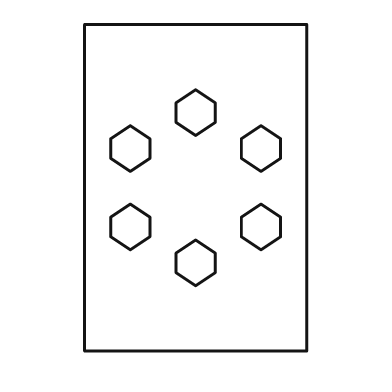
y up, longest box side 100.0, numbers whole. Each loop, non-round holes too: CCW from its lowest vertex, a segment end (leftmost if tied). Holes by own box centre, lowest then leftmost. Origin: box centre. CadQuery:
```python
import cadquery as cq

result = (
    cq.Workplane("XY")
    .moveTo(-34.0, -50.0)
    .lineTo(34.0, -50.0)
    .lineTo(34.0, 50.0)
    .lineTo(-34.0, 50.0)
    .close()
    .moveTo(0.0, -30.0)
    .lineTo(6.0, -26.0)
    .lineTo(6.0, -20.0)
    .lineTo(0.0, -16.0)
    .lineTo(-6.0, -20.0)
    .lineTo(-6.0, -26.0)
    .close()
    .moveTo(-20.0, -19.0)
    .lineTo(-14.0, -15.0)
    .lineTo(-14.0, -9.0)
    .lineTo(-20.0, -5.0)
    .lineTo(-26.0, -9.0)
    .lineTo(-26.0, -15.0)
    .close()
    .moveTo(20.0, -19.0)
    .lineTo(26.0, -15.0)
    .lineTo(26.0, -9.0)
    .lineTo(20.0, -5.0)
    .lineTo(14.0, -9.0)
    .lineTo(14.0, -15.0)
    .close()
    .moveTo(-20.0, 5.0)
    .lineTo(-14.0, 9.0)
    .lineTo(-14.0, 15.0)
    .lineTo(-20.0, 19.0)
    .lineTo(-26.0, 15.0)
    .lineTo(-26.0, 9.0)
    .close()
    .moveTo(20.0, 5.0)
    .lineTo(26.0, 9.0)
    .lineTo(26.0, 15.0)
    .lineTo(20.0, 19.0)
    .lineTo(14.0, 15.0)
    .lineTo(14.0, 9.0)
    .close()
    .moveTo(0.0, 16.0)
    .lineTo(6.0, 20.0)
    .lineTo(6.0, 26.0)
    .lineTo(0.0, 30.0)
    .lineTo(-6.0, 26.0)
    .lineTo(-6.0, 20.0)
    .close()
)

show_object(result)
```